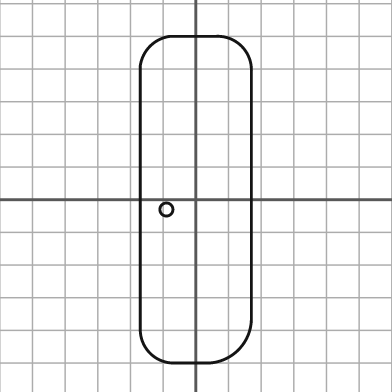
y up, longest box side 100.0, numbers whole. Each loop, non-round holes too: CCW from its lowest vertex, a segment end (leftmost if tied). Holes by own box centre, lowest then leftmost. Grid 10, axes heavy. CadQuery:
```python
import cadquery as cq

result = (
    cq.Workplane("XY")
    .moveTo(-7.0, -50.0)
    .lineTo(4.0, -50.0)
    .threePointArc((13.0, -46.0), (17.0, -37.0))
    .lineTo(17.0, 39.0)
    .threePointArc((14.0, 47.0), (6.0, 50.0))
    .lineTo(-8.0, 50.0)
    .threePointArc((-14.0, 47.0), (-17.0, 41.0))
    .lineTo(-17.0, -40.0)
    .threePointArc((-14.0, -47.0), (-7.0, -50.0))
    .close()
    .moveTo(-9.0, -3.0)
    .circle(2.0)
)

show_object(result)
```